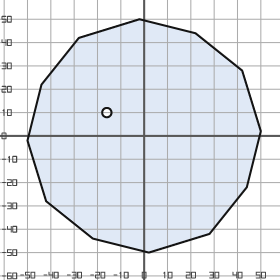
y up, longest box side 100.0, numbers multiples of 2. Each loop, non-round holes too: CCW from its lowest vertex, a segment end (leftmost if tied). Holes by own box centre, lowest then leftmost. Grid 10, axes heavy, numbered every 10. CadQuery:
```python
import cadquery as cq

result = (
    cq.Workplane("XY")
    .moveTo(2.0, -50.0)
    .lineTo(28.0, -42.0)
    .lineTo(44.0, -22.0)
    .lineTo(50.0, 2.0)
    .lineTo(42.0, 28.0)
    .lineTo(22.0, 44.0)
    .lineTo(-2.0, 50.0)
    .lineTo(-28.0, 42.0)
    .lineTo(-44.0, 22.0)
    .lineTo(-50.0, -2.0)
    .lineTo(-42.0, -28.0)
    .lineTo(-22.0, -44.0)
    .close()
    .moveTo(-16.0, 10.0)
    .circle(2.0)
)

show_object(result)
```